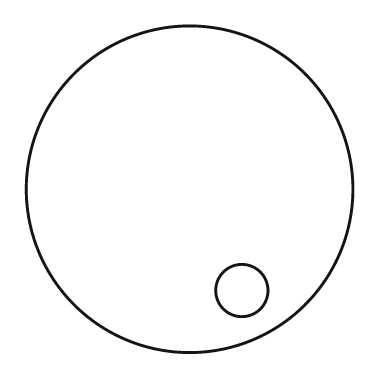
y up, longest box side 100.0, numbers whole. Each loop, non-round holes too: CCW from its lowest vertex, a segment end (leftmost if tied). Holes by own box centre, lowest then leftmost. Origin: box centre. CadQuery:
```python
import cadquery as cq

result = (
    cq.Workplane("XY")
    .moveTo(0.0, 0.0)
    .circle(50.0)
    .moveTo(16.0, -31.0)
    .circle(8.0)
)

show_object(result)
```